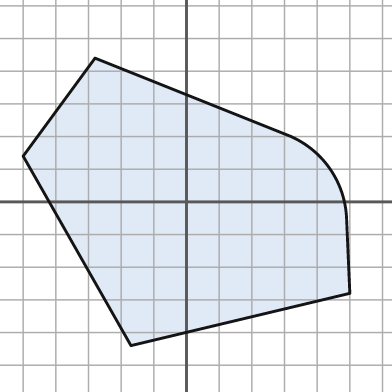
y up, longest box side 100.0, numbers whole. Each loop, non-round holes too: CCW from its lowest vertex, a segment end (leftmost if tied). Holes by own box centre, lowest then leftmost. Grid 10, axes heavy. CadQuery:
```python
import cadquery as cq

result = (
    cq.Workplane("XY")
    .moveTo(-17.0, -44.0)
    .lineTo(50.0, -28.0)
    .lineTo(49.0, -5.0)
    .threePointArc((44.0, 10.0), (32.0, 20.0))
    .lineTo(-28.0, 44.0)
    .lineTo(-50.0, 14.0)
    .close()
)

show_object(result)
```